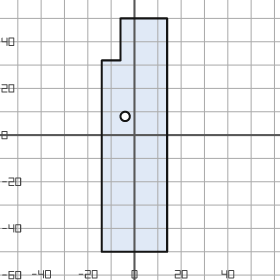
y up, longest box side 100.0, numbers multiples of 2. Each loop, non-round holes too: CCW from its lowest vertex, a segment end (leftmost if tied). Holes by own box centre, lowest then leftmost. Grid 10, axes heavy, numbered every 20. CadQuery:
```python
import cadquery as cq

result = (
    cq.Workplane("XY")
    .moveTo(-14.0, -50.0)
    .lineTo(14.0, -50.0)
    .lineTo(14.0, 50.0)
    .lineTo(-6.0, 50.0)
    .lineTo(-6.0, 32.0)
    .lineTo(-14.0, 32.0)
    .close()
    .moveTo(-4.0, 8.0)
    .circle(2.0)
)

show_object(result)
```